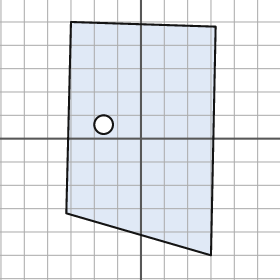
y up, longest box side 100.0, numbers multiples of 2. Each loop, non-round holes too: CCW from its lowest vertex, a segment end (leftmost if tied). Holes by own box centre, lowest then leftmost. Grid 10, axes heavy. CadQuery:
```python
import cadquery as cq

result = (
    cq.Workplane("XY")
    .moveTo(30.0, -50.0)
    .lineTo(32.0, 48.0)
    .lineTo(-30.0, 50.0)
    .lineTo(-32.0, -32.0)
    .close()
    .moveTo(-16.0, 6.0)
    .circle(4.0)
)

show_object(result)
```